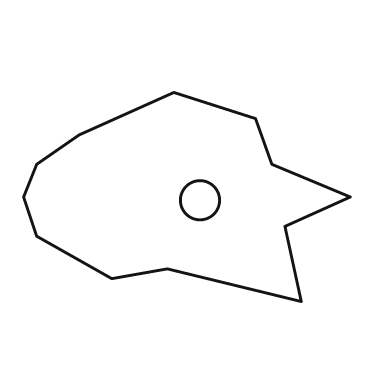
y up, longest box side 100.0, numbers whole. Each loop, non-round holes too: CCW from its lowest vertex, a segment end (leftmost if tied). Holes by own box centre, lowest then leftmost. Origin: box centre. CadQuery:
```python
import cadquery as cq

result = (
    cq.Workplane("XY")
    .moveTo(35.0, -32.0)
    .lineTo(30.0, -9.0)
    .lineTo(50.0, 0.0)
    .lineTo(26.0, 10.0)
    .lineTo(21.0, 24.0)
    .lineTo(-4.0, 32.0)
    .lineTo(-33.0, 19.0)
    .lineTo(-46.0, 10.0)
    .lineTo(-50.0, 0.0)
    .lineTo(-46.0, -12.0)
    .lineTo(-23.0, -25.0)
    .lineTo(-6.0, -22.0)
    .close()
    .moveTo(4.0, -1.0)
    .circle(6.0)
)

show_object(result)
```